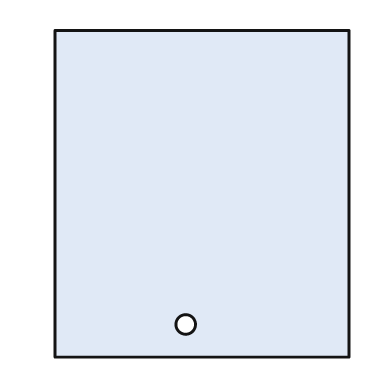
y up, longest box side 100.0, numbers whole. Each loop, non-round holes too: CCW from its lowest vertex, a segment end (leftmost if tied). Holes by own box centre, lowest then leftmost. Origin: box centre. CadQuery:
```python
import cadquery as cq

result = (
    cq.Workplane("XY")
    .moveTo(-45.0, -50.0)
    .lineTo(45.0, -50.0)
    .lineTo(45.0, 50.0)
    .lineTo(-45.0, 50.0)
    .close()
    .moveTo(-5.0, -40.0)
    .circle(3.0)
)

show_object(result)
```